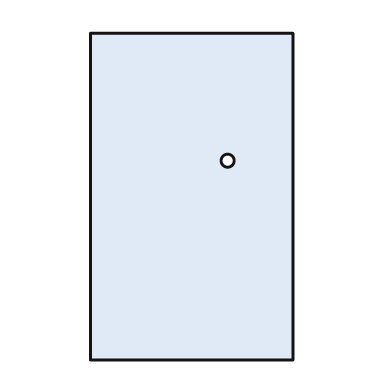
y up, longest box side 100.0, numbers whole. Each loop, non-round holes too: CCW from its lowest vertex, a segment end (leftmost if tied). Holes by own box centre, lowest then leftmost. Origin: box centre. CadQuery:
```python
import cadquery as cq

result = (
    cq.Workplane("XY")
    .moveTo(-31.0, -50.0)
    .lineTo(31.0, -50.0)
    .lineTo(31.0, 50.0)
    .lineTo(-31.0, 50.0)
    .close()
    .moveTo(11.0, 11.0)
    .circle(2.0)
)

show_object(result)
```